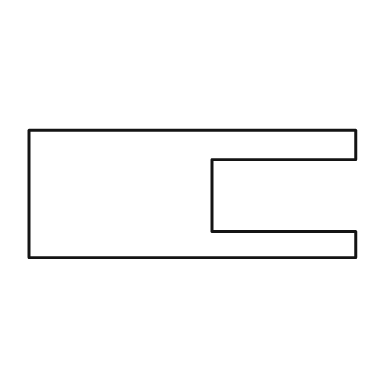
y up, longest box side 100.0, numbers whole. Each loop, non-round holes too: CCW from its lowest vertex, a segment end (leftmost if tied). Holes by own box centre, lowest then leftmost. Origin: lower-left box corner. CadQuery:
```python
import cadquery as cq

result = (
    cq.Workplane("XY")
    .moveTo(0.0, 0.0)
    .lineTo(100.0, 0.0)
    .lineTo(100.0, 8.0)
    .lineTo(56.0, 8.0)
    .lineTo(56.0, 30.0)
    .lineTo(100.0, 30.0)
    .lineTo(100.0, 39.0)
    .lineTo(0.0, 39.0)
    .close()
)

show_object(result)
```